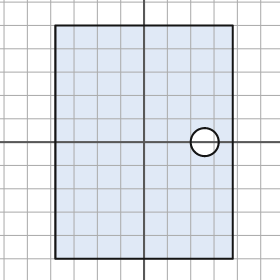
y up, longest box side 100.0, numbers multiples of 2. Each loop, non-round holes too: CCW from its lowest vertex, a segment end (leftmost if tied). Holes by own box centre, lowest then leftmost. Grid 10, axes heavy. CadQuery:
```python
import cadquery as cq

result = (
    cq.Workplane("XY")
    .moveTo(-38.0, -50.0)
    .lineTo(38.0, -50.0)
    .lineTo(38.0, 50.0)
    .lineTo(-38.0, 50.0)
    .close()
    .moveTo(26.0, 0.0)
    .circle(6.0)
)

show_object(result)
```